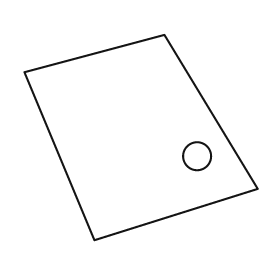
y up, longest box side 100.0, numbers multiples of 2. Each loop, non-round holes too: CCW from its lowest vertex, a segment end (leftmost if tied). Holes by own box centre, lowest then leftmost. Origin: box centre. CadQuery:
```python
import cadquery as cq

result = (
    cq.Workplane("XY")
    .moveTo(-20.0, -44.0)
    .lineTo(50.0, -22.0)
    .lineTo(10.0, 44.0)
    .lineTo(-50.0, 28.0)
    .close()
    .moveTo(24.0, -8.0)
    .circle(6.0)
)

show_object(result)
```